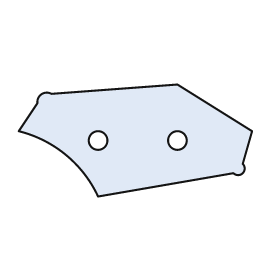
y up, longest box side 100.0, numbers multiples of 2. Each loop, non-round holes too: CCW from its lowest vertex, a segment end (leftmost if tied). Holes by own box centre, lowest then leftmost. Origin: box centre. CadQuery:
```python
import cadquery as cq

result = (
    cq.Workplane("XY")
    .moveTo(-16.0, -24.0)
    .lineTo(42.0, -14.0)
    .threePointArc((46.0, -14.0), (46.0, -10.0))
    .lineTo(50.0, 4.0)
    .lineTo(18.0, 24.0)
    .lineTo(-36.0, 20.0)
    .threePointArc((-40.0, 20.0), (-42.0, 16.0))
    .lineTo(-50.0, 4.0)
    .threePointArc((-30.0, -6.0), (-16.0, -24.0))
    .close()
    .moveTo(-16.0, 0.0)
    .circle(4.0)
    .moveTo(18.0, 0.0)
    .circle(4.0)
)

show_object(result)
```